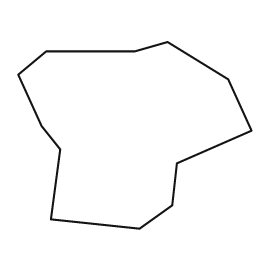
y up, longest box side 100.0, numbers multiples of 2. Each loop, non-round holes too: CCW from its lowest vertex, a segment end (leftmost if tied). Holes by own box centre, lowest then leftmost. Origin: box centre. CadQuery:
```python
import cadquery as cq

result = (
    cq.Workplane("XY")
    .moveTo(2.0, -40.0)
    .lineTo(16.0, -30.0)
    .lineTo(18.0, -12.0)
    .lineTo(50.0, 2.0)
    .lineTo(40.0, 24.0)
    .lineTo(14.0, 40.0)
    .lineTo(0.0, 36.0)
    .lineTo(-38.0, 36.0)
    .lineTo(-50.0, 26.0)
    .lineTo(-40.0, 4.0)
    .lineTo(-32.0, -6.0)
    .lineTo(-36.0, -36.0)
    .close()
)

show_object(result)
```